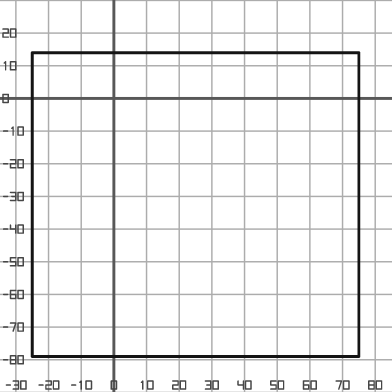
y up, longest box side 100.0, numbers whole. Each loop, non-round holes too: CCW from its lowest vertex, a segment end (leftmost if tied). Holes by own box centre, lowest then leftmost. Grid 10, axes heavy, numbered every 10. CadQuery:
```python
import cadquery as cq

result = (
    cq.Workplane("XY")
    .moveTo(-25.0, -79.0)
    .lineTo(75.0, -79.0)
    .lineTo(75.0, 14.0)
    .lineTo(-25.0, 14.0)
    .close()
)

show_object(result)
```